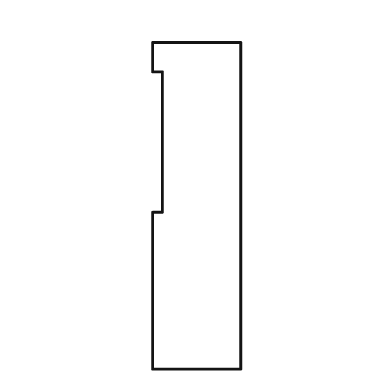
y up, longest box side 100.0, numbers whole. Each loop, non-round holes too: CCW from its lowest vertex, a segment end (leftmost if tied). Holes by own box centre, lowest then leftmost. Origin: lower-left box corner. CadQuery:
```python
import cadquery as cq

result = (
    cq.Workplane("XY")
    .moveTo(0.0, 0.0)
    .lineTo(27.0, 0.0)
    .lineTo(27.0, 100.0)
    .lineTo(0.0, 100.0)
    .lineTo(0.0, 91.0)
    .lineTo(3.0, 91.0)
    .lineTo(3.0, 48.0)
    .lineTo(0.0, 48.0)
    .close()
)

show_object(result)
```